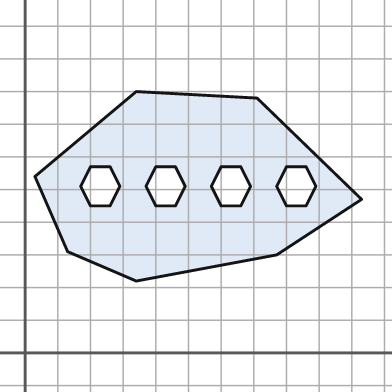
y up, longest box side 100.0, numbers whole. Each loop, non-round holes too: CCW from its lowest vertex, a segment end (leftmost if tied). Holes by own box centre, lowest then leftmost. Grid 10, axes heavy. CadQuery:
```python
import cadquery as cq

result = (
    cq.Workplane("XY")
    .moveTo(34.0, 22.0)
    .lineTo(77.0, 30.0)
    .lineTo(103.0, 47.0)
    .lineTo(71.0, 78.0)
    .lineTo(34.0, 80.0)
    .lineTo(3.0, 54.0)
    .lineTo(13.0, 31.0)
    .close()
    .moveTo(20.0, 45.0)
    .lineTo(26.0, 45.0)
    .lineTo(29.0, 51.0)
    .lineTo(26.0, 57.0)
    .lineTo(20.0, 57.0)
    .lineTo(17.0, 51.0)
    .close()
    .moveTo(40.0, 45.0)
    .lineTo(46.0, 45.0)
    .lineTo(49.0, 51.0)
    .lineTo(46.0, 57.0)
    .lineTo(40.0, 57.0)
    .lineTo(37.0, 51.0)
    .close()
    .moveTo(60.0, 45.0)
    .lineTo(66.0, 45.0)
    .lineTo(69.0, 51.0)
    .lineTo(66.0, 57.0)
    .lineTo(60.0, 57.0)
    .lineTo(57.0, 51.0)
    .close()
    .moveTo(80.0, 45.0)
    .lineTo(86.0, 45.0)
    .lineTo(89.0, 51.0)
    .lineTo(86.0, 57.0)
    .lineTo(80.0, 57.0)
    .lineTo(77.0, 51.0)
    .close()
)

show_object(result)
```